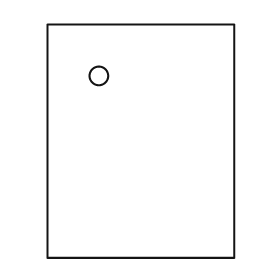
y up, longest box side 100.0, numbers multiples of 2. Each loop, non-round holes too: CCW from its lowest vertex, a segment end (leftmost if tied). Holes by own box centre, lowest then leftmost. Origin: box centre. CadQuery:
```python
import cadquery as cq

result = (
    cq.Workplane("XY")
    .moveTo(-40.0, -50.0)
    .lineTo(40.0, -50.0)
    .lineTo(40.0, 50.0)
    .lineTo(-40.0, 50.0)
    .close()
    .moveTo(-18.0, 28.0)
    .circle(4.0)
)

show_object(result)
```